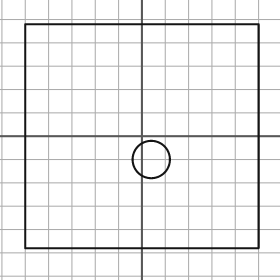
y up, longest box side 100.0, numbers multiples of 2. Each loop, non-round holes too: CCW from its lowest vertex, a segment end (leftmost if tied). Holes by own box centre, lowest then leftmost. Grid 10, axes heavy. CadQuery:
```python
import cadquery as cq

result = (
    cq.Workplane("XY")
    .moveTo(-50.0, -48.0)
    .lineTo(50.0, -48.0)
    .lineTo(50.0, 48.0)
    .lineTo(-50.0, 48.0)
    .close()
    .moveTo(4.0, -10.0)
    .circle(8.0)
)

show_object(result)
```